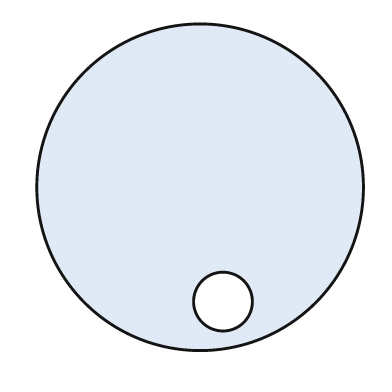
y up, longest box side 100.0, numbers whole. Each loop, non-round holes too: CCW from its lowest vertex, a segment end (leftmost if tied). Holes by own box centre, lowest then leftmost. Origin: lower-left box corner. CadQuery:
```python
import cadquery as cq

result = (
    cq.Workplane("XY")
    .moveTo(50.0, 50.0)
    .circle(50.0)
    .moveTo(57.0, 15.0)
    .circle(9.0)
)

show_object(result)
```